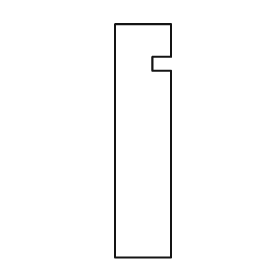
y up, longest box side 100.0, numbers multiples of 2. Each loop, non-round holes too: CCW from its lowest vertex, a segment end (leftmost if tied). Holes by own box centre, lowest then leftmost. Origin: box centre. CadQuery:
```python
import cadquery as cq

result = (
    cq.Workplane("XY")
    .moveTo(-12.0, -50.0)
    .lineTo(12.0, -50.0)
    .lineTo(12.0, 30.0)
    .lineTo(4.0, 30.0)
    .lineTo(4.0, 36.0)
    .lineTo(12.0, 36.0)
    .lineTo(12.0, 50.0)
    .lineTo(-12.0, 50.0)
    .close()
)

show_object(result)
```